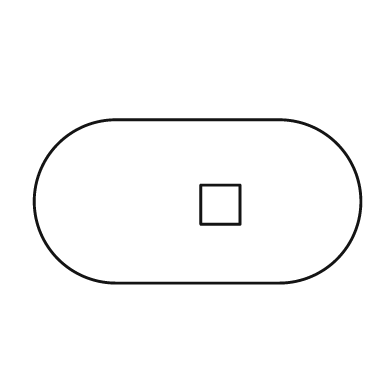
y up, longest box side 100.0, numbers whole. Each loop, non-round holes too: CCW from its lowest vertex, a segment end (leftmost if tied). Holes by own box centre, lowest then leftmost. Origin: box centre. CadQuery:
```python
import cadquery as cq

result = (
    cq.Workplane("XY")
    .moveTo(-25.0, -25.0)
    .lineTo(25.0, -25.0)
    .threePointArc((50.0, 0.0), (25.0, 25.0))
    .lineTo(-25.0, 25.0)
    .threePointArc((-50.0, 0.0), (-25.0, -25.0))
    .close()
    .moveTo(1.0, -7.0)
    .lineTo(13.0, -7.0)
    .lineTo(13.0, 5.0)
    .lineTo(1.0, 5.0)
    .close()
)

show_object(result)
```